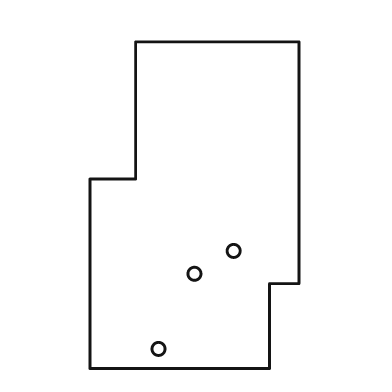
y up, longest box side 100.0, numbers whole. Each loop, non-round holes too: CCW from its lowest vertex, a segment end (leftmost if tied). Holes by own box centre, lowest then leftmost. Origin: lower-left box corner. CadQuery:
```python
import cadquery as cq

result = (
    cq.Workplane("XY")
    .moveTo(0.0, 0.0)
    .lineTo(55.0, 0.0)
    .lineTo(55.0, 26.0)
    .lineTo(64.0, 26.0)
    .lineTo(64.0, 100.0)
    .lineTo(14.0, 100.0)
    .lineTo(14.0, 58.0)
    .lineTo(0.0, 58.0)
    .close()
    .moveTo(21.0, 6.0)
    .circle(2.0)
    .moveTo(32.0, 29.0)
    .circle(2.0)
    .moveTo(44.0, 36.0)
    .circle(2.0)
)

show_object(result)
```